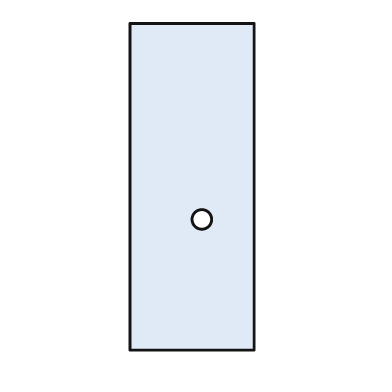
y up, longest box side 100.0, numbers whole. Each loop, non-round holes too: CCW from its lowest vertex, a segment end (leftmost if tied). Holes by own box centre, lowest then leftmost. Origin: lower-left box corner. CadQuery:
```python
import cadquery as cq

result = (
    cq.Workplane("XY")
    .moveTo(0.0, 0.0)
    .lineTo(38.0, 0.0)
    .lineTo(38.0, 100.0)
    .lineTo(0.0, 100.0)
    .close()
    .moveTo(22.0, 40.0)
    .circle(3.0)
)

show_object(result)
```